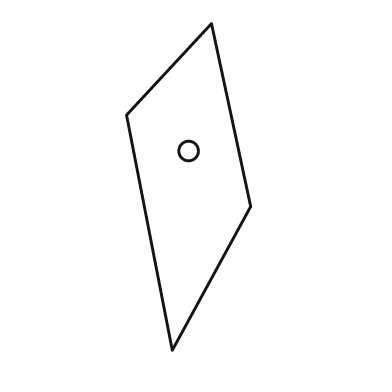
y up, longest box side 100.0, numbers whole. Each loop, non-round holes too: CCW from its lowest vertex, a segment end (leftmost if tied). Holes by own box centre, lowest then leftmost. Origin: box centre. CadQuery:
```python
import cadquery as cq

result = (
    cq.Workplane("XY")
    .moveTo(-5.0, -50.0)
    .lineTo(19.0, -6.0)
    .lineTo(7.0, 50.0)
    .lineTo(-19.0, 22.0)
    .close()
    .moveTo(0.0, 11.0)
    .circle(3.0)
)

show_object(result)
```